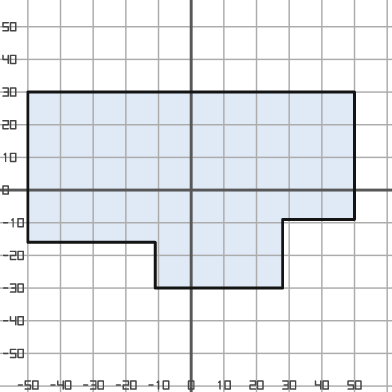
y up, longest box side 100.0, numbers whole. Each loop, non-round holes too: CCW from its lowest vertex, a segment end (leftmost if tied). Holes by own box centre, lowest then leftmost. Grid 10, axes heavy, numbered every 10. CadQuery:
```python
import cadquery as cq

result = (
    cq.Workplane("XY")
    .moveTo(-11.0, -30.0)
    .lineTo(28.0, -30.0)
    .lineTo(28.0, -9.0)
    .lineTo(50.0, -9.0)
    .lineTo(50.0, 30.0)
    .lineTo(-50.0, 30.0)
    .lineTo(-50.0, -16.0)
    .lineTo(-11.0, -16.0)
    .close()
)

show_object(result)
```